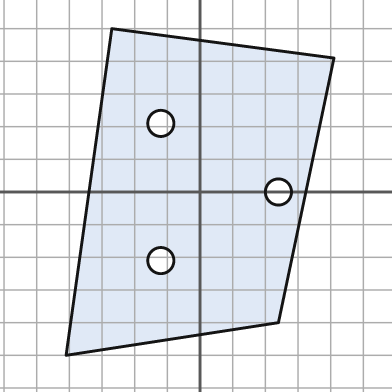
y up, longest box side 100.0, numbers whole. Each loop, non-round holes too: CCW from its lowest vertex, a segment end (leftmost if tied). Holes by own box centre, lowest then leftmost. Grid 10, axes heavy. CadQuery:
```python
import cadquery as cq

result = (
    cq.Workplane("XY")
    .moveTo(-41.0, -50.0)
    .lineTo(24.0, -40.0)
    .lineTo(41.0, 41.0)
    .lineTo(-27.0, 50.0)
    .close()
    .moveTo(-12.0, -21.0)
    .circle(4.0)
    .moveTo(24.0, 0.0)
    .circle(4.0)
    .moveTo(-12.0, 21.0)
    .circle(4.0)
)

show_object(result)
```